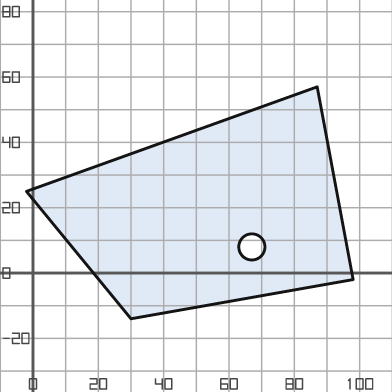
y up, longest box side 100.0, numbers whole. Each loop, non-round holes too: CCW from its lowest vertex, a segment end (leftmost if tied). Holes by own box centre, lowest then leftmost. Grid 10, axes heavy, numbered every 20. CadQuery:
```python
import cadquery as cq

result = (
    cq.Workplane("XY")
    .moveTo(30.0, -14.0)
    .lineTo(98.0, -2.0)
    .lineTo(87.0, 57.0)
    .lineTo(-2.0, 25.0)
    .close()
    .moveTo(67.0, 8.0)
    .circle(4.0)
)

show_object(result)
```